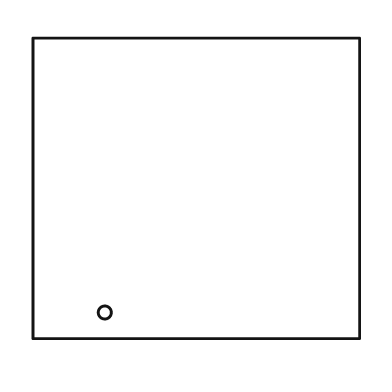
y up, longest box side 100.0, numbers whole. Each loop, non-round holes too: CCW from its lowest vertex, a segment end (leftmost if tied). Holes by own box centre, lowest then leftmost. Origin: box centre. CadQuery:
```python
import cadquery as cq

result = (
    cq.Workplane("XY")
    .moveTo(-50.0, -46.0)
    .lineTo(50.0, -46.0)
    .lineTo(50.0, 46.0)
    .lineTo(-50.0, 46.0)
    .close()
    .moveTo(-28.0, -38.0)
    .circle(2.0)
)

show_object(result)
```